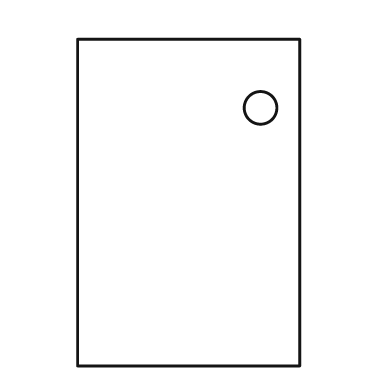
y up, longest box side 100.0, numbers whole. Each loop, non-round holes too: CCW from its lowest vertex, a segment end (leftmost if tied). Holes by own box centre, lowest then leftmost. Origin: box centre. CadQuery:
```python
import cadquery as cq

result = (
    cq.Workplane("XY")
    .moveTo(-34.0, -50.0)
    .lineTo(34.0, -50.0)
    .lineTo(34.0, 50.0)
    .lineTo(-34.0, 50.0)
    .close()
    .moveTo(22.0, 29.0)
    .circle(5.0)
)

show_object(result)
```